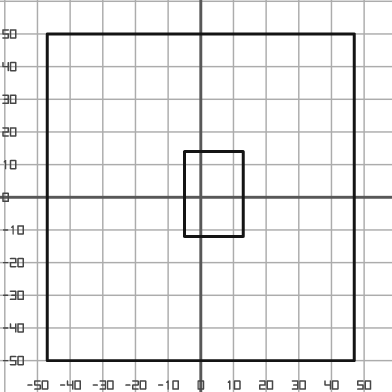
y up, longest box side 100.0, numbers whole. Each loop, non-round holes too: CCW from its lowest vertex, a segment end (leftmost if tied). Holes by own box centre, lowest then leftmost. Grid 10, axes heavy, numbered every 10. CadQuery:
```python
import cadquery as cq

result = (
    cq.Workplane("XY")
    .moveTo(-47.0, -50.0)
    .lineTo(47.0, -50.0)
    .lineTo(47.0, 50.0)
    .lineTo(-47.0, 50.0)
    .close()
    .moveTo(-5.0, -12.0)
    .lineTo(13.0, -12.0)
    .lineTo(13.0, 14.0)
    .lineTo(-5.0, 14.0)
    .close()
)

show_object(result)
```